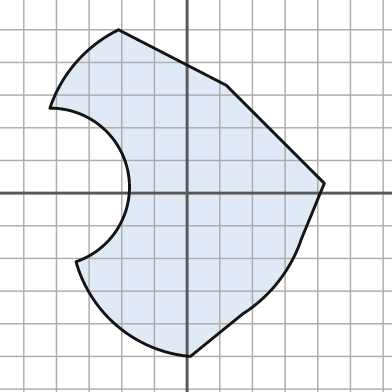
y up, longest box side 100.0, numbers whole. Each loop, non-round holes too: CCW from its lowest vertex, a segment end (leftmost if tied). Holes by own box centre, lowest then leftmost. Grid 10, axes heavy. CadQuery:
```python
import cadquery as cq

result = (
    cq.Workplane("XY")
    .moveTo(1.0, -50.0)
    .lineTo(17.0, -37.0)
    .threePointArc((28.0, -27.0), (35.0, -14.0))
    .lineTo(42.0, 3.0)
    .lineTo(12.0, 33.0)
    .lineTo(-21.0, 50.0)
    .threePointArc((-34.0, 40.0), (-42.0, 26.0))
    .threePointArc((-18.0, 6.0), (-34.0, -21.0))
    .threePointArc((-21.0, -41.0), (1.0, -50.0))
    .close()
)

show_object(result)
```